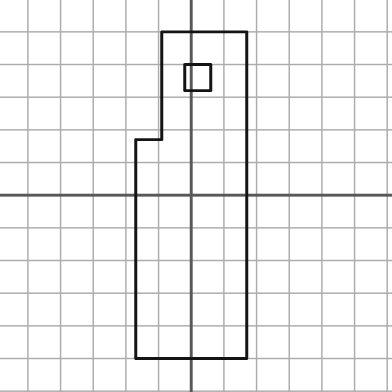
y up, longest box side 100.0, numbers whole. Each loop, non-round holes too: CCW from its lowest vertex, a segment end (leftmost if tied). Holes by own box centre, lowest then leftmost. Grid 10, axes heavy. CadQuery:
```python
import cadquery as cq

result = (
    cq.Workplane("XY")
    .moveTo(-17.0, -50.0)
    .lineTo(17.0, -50.0)
    .lineTo(17.0, 50.0)
    .lineTo(-9.0, 50.0)
    .lineTo(-9.0, 17.0)
    .lineTo(-17.0, 17.0)
    .close()
    .moveTo(-2.0, 32.0)
    .lineTo(6.0, 32.0)
    .lineTo(6.0, 40.0)
    .lineTo(-2.0, 40.0)
    .close()
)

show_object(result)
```